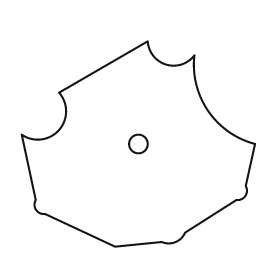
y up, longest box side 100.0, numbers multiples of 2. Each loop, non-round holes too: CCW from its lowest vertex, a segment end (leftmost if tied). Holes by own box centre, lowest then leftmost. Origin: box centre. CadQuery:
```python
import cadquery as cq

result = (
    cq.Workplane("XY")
    .moveTo(-10.0, -44.0)
    .lineTo(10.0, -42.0)
    .threePointArc((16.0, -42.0), (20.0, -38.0))
    .lineTo(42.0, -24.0)
    .threePointArc((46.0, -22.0), (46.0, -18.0))
    .lineTo(50.0, 0.0)
    .threePointArc((30.0, 14.0), (24.0, 38.0))
    .threePointArc((12.0, 34.0), (4.0, 44.0))
    .lineTo(-34.0, 22.0)
    .threePointArc((-34.0, 6.0), (-50.0, 4.0))
    .lineTo(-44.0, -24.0)
    .threePointArc((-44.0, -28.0), (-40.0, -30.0))
    .close()
    .moveTo(0.0, 0.0)
    .circle(4.0)
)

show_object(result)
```